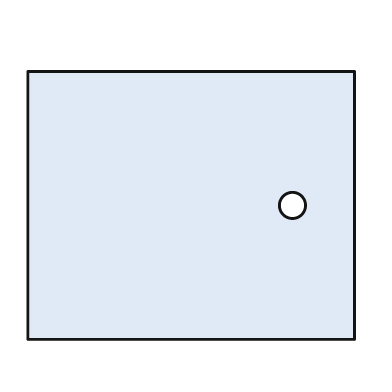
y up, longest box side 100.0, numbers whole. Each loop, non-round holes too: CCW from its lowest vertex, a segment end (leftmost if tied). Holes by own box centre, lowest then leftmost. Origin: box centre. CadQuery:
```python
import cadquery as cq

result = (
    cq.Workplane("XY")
    .moveTo(-50.0, -41.0)
    .lineTo(50.0, -41.0)
    .lineTo(50.0, 41.0)
    .lineTo(-50.0, 41.0)
    .close()
    .moveTo(31.0, 0.0)
    .circle(4.0)
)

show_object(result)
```